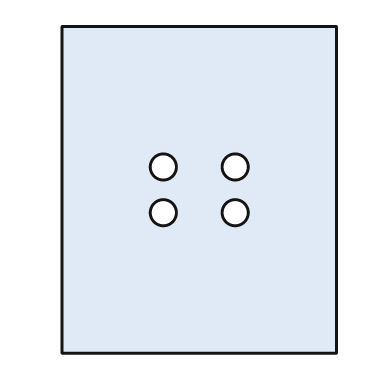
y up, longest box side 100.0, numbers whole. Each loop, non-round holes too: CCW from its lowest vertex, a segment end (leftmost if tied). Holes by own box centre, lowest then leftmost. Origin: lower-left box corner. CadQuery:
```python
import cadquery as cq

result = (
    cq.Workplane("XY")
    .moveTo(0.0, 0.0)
    .lineTo(84.0, 0.0)
    .lineTo(84.0, 100.0)
    .lineTo(0.0, 100.0)
    .close()
    .moveTo(31.0, 43.0)
    .circle(4.0)
    .moveTo(53.0, 43.0)
    .circle(4.0)
    .moveTo(31.0, 57.0)
    .circle(4.0)
    .moveTo(53.0, 57.0)
    .circle(4.0)
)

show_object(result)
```